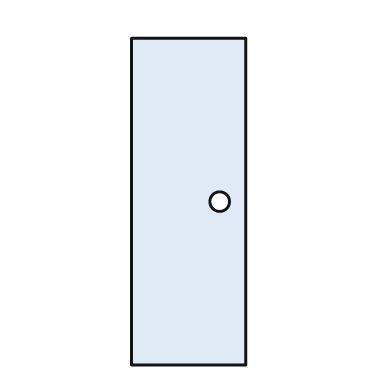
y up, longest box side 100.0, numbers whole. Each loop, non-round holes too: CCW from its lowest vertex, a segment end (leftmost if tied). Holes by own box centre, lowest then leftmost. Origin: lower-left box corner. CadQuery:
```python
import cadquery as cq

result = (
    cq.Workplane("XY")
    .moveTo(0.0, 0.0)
    .lineTo(35.0, 0.0)
    .lineTo(35.0, 100.0)
    .lineTo(0.0, 100.0)
    .close()
    .moveTo(27.0, 50.0)
    .circle(3.0)
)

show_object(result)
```